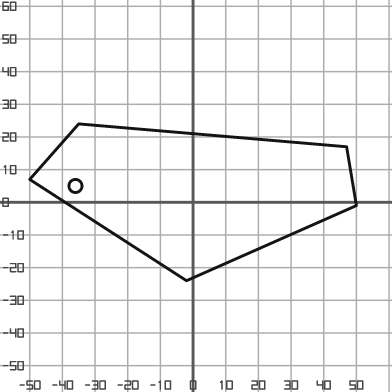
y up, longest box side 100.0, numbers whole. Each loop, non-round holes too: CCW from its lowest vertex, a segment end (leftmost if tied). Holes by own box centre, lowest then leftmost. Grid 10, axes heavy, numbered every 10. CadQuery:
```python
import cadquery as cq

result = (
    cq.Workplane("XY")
    .moveTo(-2.0, -24.0)
    .lineTo(50.0, -1.0)
    .lineTo(47.0, 17.0)
    .lineTo(-35.0, 24.0)
    .lineTo(-50.0, 7.0)
    .close()
    .moveTo(-36.0, 5.0)
    .circle(2.0)
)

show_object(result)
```